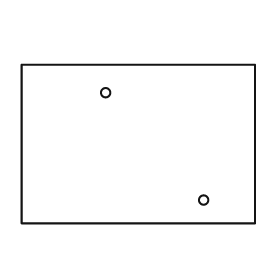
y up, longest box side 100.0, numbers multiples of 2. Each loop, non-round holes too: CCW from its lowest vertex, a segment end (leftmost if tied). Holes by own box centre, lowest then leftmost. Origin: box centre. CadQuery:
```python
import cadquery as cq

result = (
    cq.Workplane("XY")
    .moveTo(-50.0, -34.0)
    .lineTo(50.0, -34.0)
    .lineTo(50.0, 34.0)
    .lineTo(-50.0, 34.0)
    .close()
    .moveTo(28.0, -24.0)
    .circle(2.0)
    .moveTo(-14.0, 22.0)
    .circle(2.0)
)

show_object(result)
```